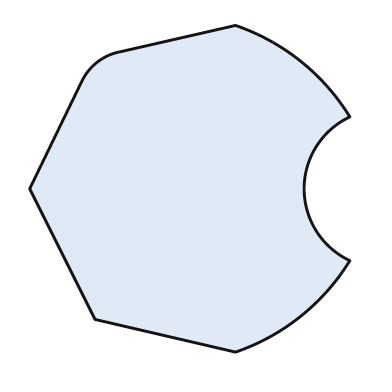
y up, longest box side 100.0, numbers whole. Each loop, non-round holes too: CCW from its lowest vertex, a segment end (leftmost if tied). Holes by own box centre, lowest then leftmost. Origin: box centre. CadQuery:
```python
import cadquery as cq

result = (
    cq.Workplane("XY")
    .moveTo(14.0, -50.0)
    .threePointArc((34.0, -39.0), (49.0, -22.0))
    .threePointArc((35.0, 0.0), (49.0, 22.0))
    .threePointArc((34.0, 39.0), (14.0, 50.0))
    .lineTo(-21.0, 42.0)
    .threePointArc((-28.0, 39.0), (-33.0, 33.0))
    .lineTo(-49.0, 0.0)
    .lineTo(-29.0, -40.0)
    .close()
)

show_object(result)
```